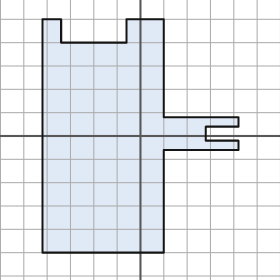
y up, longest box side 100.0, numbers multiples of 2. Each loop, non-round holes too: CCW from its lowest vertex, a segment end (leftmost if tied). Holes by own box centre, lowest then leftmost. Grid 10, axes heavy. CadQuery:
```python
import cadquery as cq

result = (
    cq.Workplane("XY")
    .moveTo(-42.0, -50.0)
    .lineTo(10.0, -50.0)
    .lineTo(10.0, -6.0)
    .lineTo(42.0, -6.0)
    .lineTo(42.0, -2.0)
    .lineTo(28.0, -2.0)
    .lineTo(28.0, 4.0)
    .lineTo(42.0, 4.0)
    .lineTo(42.0, 8.0)
    .lineTo(10.0, 8.0)
    .lineTo(10.0, 50.0)
    .lineTo(-6.0, 50.0)
    .lineTo(-6.0, 40.0)
    .lineTo(-34.0, 40.0)
    .lineTo(-34.0, 50.0)
    .lineTo(-42.0, 50.0)
    .close()
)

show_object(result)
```